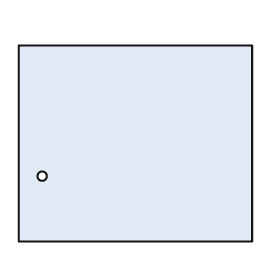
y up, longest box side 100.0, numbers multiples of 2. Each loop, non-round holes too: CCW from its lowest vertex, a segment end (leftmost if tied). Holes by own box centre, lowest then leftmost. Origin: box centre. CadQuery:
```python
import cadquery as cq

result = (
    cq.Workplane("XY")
    .moveTo(-50.0, -42.0)
    .lineTo(50.0, -42.0)
    .lineTo(50.0, 42.0)
    .lineTo(-50.0, 42.0)
    .close()
    .moveTo(-40.0, -14.0)
    .circle(2.0)
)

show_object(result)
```